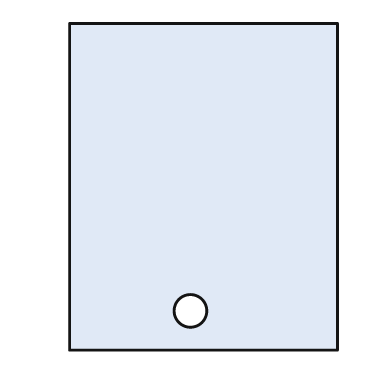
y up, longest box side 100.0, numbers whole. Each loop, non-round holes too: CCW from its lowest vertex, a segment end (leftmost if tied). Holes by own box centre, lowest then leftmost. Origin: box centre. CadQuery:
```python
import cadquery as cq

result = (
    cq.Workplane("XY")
    .moveTo(-41.0, -50.0)
    .lineTo(41.0, -50.0)
    .lineTo(41.0, 50.0)
    .lineTo(-41.0, 50.0)
    .close()
    .moveTo(-4.0, -38.0)
    .circle(5.0)
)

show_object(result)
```